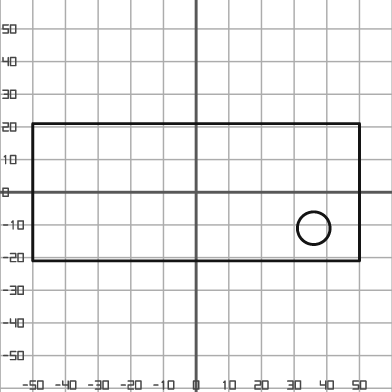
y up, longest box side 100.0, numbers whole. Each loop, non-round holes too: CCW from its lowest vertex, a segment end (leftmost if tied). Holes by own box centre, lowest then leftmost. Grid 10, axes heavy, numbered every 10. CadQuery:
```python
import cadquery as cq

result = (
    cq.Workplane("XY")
    .moveTo(-50.0, -21.0)
    .lineTo(50.0, -21.0)
    .lineTo(50.0, 21.0)
    .lineTo(-50.0, 21.0)
    .close()
    .moveTo(36.0, -11.0)
    .circle(5.0)
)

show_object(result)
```